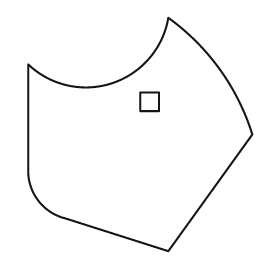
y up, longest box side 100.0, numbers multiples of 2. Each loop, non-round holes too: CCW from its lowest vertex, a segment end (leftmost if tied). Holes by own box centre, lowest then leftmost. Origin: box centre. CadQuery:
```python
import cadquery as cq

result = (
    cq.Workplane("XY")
    .moveTo(12.0, -50.0)
    .lineTo(48.0, 0.0)
    .threePointArc((34.0, 28.0), (12.0, 50.0))
    .threePointArc((-12.0, 22.0), (-48.0, 30.0))
    .lineTo(-48.0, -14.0)
    .threePointArc((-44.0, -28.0), (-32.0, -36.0))
    .close()
    .moveTo(0.0, 10.0)
    .lineTo(8.0, 10.0)
    .lineTo(8.0, 18.0)
    .lineTo(0.0, 18.0)
    .close()
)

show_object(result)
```